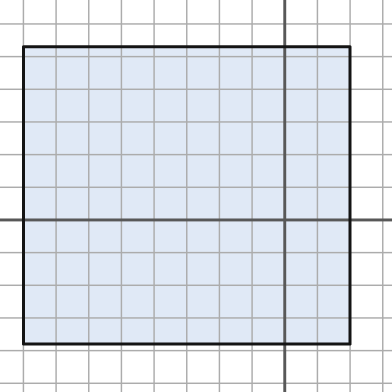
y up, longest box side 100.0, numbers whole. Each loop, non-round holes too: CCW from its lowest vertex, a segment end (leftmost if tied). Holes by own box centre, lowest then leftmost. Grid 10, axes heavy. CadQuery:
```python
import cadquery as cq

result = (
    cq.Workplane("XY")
    .moveTo(-80.0, -38.0)
    .lineTo(20.0, -38.0)
    .lineTo(20.0, 53.0)
    .lineTo(-80.0, 53.0)
    .close()
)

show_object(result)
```